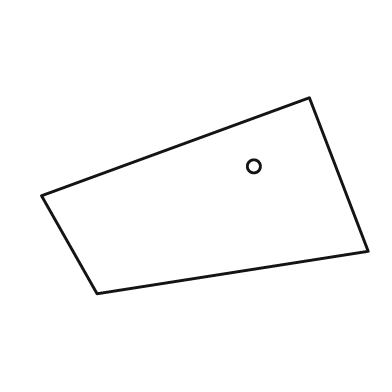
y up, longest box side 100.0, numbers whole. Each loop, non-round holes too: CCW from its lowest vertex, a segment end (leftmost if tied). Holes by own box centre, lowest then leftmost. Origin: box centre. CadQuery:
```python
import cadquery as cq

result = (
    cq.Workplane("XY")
    .moveTo(-33.0, -30.0)
    .lineTo(50.0, -17.0)
    .lineTo(32.0, 30.0)
    .lineTo(-50.0, 0.0)
    .close()
    .moveTo(15.0, 9.0)
    .circle(2.0)
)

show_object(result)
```